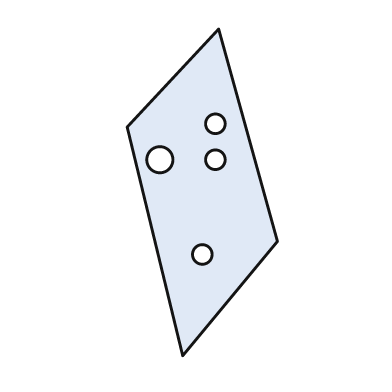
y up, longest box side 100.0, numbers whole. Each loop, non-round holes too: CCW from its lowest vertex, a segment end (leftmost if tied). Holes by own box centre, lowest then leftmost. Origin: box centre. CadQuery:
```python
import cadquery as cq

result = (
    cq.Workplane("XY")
    .moveTo(-6.0, -50.0)
    .lineTo(23.0, -15.0)
    .lineTo(5.0, 50.0)
    .lineTo(-23.0, 20.0)
    .close()
    .moveTo(0.0, -19.0)
    .circle(3.0)
    .moveTo(-13.0, 10.0)
    .circle(4.0)
    .moveTo(4.0, 10.0)
    .circle(3.0)
    .moveTo(4.0, 21.0)
    .circle(3.0)
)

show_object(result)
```